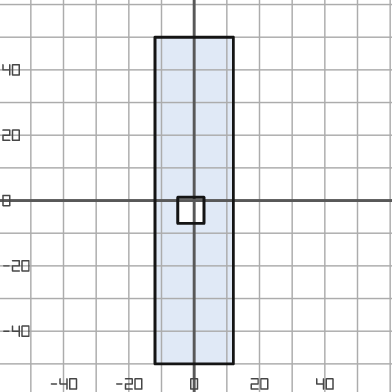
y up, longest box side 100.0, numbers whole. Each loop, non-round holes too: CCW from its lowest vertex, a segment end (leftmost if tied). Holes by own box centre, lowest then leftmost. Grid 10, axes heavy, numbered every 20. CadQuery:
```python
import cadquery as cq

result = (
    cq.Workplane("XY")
    .moveTo(-12.0, -50.0)
    .lineTo(12.0, -50.0)
    .lineTo(12.0, 50.0)
    .lineTo(-12.0, 50.0)
    .close()
    .moveTo(-5.0, -7.0)
    .lineTo(3.0, -7.0)
    .lineTo(3.0, 1.0)
    .lineTo(-5.0, 1.0)
    .close()
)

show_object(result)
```